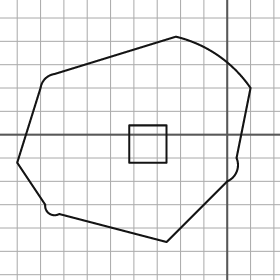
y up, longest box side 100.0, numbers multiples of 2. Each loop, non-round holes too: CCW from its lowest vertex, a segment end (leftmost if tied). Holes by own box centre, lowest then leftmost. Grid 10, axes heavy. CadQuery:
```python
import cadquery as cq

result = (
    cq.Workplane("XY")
    .moveTo(-26.0, -46.0)
    .lineTo(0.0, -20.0)
    .threePointArc((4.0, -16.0), (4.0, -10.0))
    .lineTo(10.0, 20.0)
    .threePointArc((-4.0, 34.0), (-22.0, 42.0))
    .lineTo(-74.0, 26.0)
    .threePointArc((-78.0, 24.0), (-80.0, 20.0))
    .lineTo(-90.0, -12.0)
    .lineTo(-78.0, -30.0)
    .threePointArc((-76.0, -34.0), (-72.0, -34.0))
    .close()
    .moveTo(-42.0, -12.0)
    .lineTo(-26.0, -12.0)
    .lineTo(-26.0, 4.0)
    .lineTo(-42.0, 4.0)
    .close()
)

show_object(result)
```